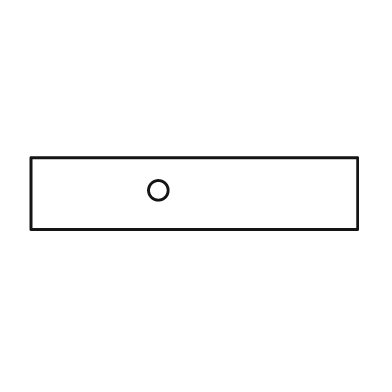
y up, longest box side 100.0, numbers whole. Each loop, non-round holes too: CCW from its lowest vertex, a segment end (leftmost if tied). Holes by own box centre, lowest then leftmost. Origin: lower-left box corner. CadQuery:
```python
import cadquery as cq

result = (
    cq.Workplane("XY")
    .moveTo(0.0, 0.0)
    .lineTo(100.0, 0.0)
    .lineTo(100.0, 22.0)
    .lineTo(0.0, 22.0)
    .close()
    .moveTo(39.0, 12.0)
    .circle(3.0)
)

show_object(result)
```